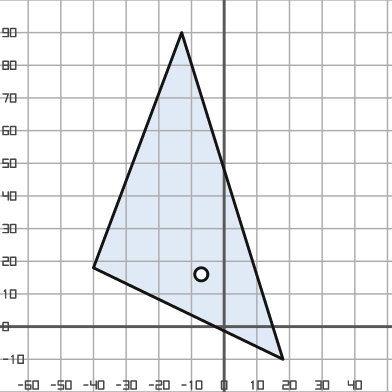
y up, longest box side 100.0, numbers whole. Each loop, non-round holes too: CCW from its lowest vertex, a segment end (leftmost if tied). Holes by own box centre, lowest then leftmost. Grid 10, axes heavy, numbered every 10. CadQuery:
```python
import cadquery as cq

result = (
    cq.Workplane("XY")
    .moveTo(18.0, -10.0)
    .lineTo(-13.0, 90.0)
    .lineTo(-40.0, 18.0)
    .close()
    .moveTo(-7.0, 16.0)
    .circle(2.0)
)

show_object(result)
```